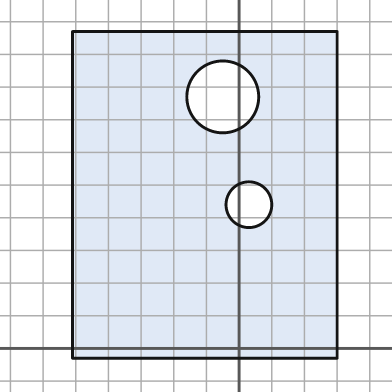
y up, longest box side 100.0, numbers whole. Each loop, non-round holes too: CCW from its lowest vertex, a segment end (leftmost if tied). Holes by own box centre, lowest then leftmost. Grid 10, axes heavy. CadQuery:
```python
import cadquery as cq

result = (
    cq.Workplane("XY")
    .moveTo(-51.0, -3.0)
    .lineTo(30.0, -3.0)
    .lineTo(30.0, 97.0)
    .lineTo(-51.0, 97.0)
    .close()
    .moveTo(3.0, 44.0)
    .circle(7.0)
    .moveTo(-5.0, 77.0)
    .circle(11.0)
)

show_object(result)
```